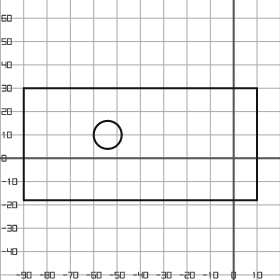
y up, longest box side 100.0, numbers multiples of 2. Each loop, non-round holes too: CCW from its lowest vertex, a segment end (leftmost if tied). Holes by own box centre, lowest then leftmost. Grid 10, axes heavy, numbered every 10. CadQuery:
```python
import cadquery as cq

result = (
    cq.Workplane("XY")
    .moveTo(-90.0, -18.0)
    .lineTo(10.0, -18.0)
    .lineTo(10.0, 30.0)
    .lineTo(-90.0, 30.0)
    .close()
    .moveTo(-54.0, 10.0)
    .circle(6.0)
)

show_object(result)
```